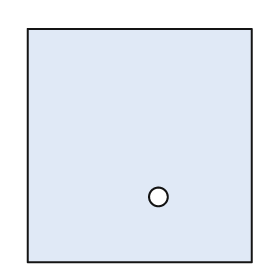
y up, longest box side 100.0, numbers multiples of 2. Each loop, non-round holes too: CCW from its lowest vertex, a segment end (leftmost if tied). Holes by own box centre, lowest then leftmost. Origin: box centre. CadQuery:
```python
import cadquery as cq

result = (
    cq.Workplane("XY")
    .moveTo(-48.0, -50.0)
    .lineTo(48.0, -50.0)
    .lineTo(48.0, 50.0)
    .lineTo(-48.0, 50.0)
    .close()
    .moveTo(8.0, -22.0)
    .circle(4.0)
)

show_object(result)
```